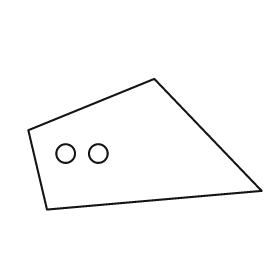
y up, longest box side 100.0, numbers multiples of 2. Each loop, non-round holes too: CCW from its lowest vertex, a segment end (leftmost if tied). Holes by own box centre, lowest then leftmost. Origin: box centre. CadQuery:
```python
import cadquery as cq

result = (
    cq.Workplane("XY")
    .moveTo(-42.0, -28.0)
    .lineTo(50.0, -20.0)
    .lineTo(4.0, 28.0)
    .lineTo(-50.0, 6.0)
    .close()
    .moveTo(-34.0, -4.0)
    .circle(4.0)
    .moveTo(-20.0, -4.0)
    .circle(4.0)
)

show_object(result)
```